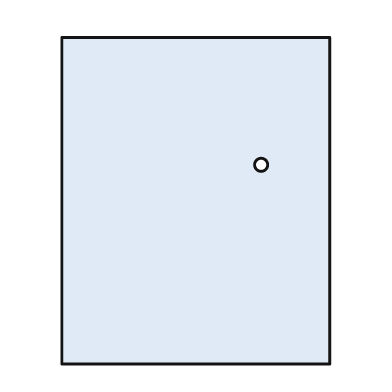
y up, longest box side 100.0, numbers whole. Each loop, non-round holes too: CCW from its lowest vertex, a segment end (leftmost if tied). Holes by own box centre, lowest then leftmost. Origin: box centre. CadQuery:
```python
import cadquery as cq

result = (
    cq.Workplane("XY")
    .moveTo(-41.0, -50.0)
    .lineTo(41.0, -50.0)
    .lineTo(41.0, 50.0)
    .lineTo(-41.0, 50.0)
    .close()
    .moveTo(20.0, 11.0)
    .circle(2.0)
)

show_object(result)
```